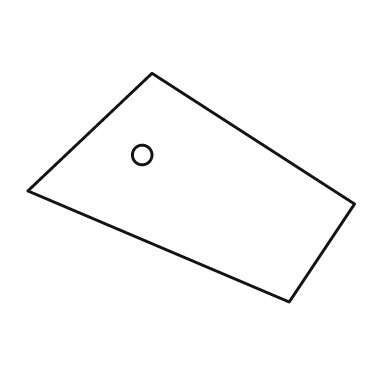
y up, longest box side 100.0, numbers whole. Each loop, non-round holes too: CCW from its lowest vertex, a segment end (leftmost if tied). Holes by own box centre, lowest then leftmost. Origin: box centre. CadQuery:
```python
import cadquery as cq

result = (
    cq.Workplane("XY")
    .moveTo(30.0, -35.0)
    .lineTo(50.0, -5.0)
    .lineTo(-12.0, 35.0)
    .lineTo(-50.0, -1.0)
    .close()
    .moveTo(-15.0, 10.0)
    .circle(3.0)
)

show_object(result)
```